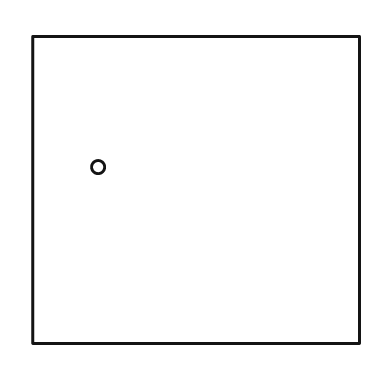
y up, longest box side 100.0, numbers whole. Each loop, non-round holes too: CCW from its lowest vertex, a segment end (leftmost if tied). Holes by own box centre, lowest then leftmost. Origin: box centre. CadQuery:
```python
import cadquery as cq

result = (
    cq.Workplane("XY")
    .moveTo(-50.0, -47.0)
    .lineTo(50.0, -47.0)
    .lineTo(50.0, 47.0)
    .lineTo(-50.0, 47.0)
    .close()
    .moveTo(-30.0, 7.0)
    .circle(2.0)
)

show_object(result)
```